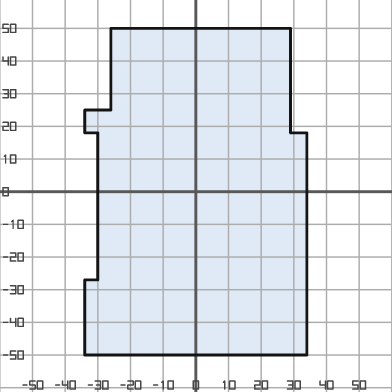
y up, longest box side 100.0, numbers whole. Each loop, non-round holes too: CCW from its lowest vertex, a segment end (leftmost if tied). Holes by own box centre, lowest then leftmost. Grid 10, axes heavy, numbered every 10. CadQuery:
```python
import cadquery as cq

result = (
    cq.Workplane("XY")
    .moveTo(-34.0, -50.0)
    .lineTo(34.0, -50.0)
    .lineTo(34.0, 18.0)
    .lineTo(29.0, 18.0)
    .lineTo(29.0, 50.0)
    .lineTo(-26.0, 50.0)
    .lineTo(-26.0, 25.0)
    .lineTo(-34.0, 25.0)
    .lineTo(-34.0, 18.0)
    .lineTo(-30.0, 18.0)
    .lineTo(-30.0, -27.0)
    .lineTo(-34.0, -27.0)
    .close()
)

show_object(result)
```